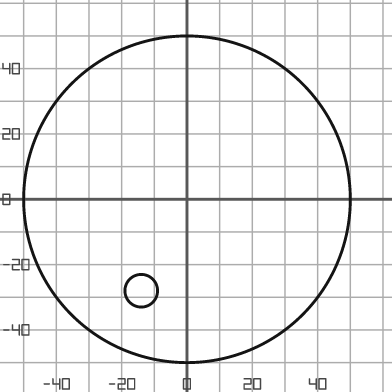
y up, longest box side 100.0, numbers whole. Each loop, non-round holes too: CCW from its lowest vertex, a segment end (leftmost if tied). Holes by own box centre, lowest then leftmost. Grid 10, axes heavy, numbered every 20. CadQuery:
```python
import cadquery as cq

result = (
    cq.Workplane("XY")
    .moveTo(0.0, 0.0)
    .circle(50.0)
    .moveTo(-14.0, -28.0)
    .circle(5.0)
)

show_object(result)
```